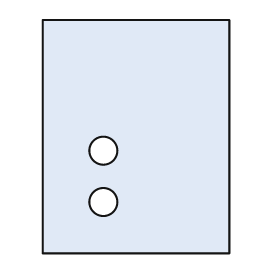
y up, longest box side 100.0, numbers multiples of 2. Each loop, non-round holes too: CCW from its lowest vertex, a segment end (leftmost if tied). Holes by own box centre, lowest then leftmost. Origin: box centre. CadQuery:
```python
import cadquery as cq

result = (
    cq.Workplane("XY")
    .moveTo(-40.0, -50.0)
    .lineTo(40.0, -50.0)
    .lineTo(40.0, 50.0)
    .lineTo(-40.0, 50.0)
    .close()
    .moveTo(-14.0, -28.0)
    .circle(6.0)
    .moveTo(-14.0, -6.0)
    .circle(6.0)
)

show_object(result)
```